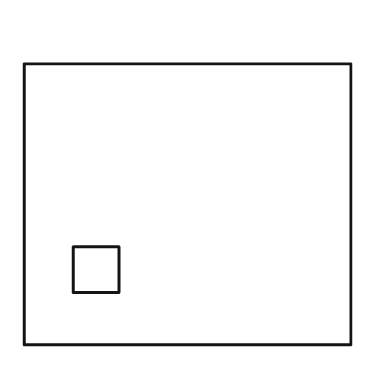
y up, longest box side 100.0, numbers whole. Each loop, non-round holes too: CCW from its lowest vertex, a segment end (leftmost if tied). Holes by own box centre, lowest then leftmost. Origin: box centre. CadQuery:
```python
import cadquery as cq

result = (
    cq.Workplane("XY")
    .moveTo(-50.0, -43.0)
    .lineTo(50.0, -43.0)
    .lineTo(50.0, 43.0)
    .lineTo(-50.0, 43.0)
    .close()
    .moveTo(-35.0, -27.0)
    .lineTo(-21.0, -27.0)
    .lineTo(-21.0, -13.0)
    .lineTo(-35.0, -13.0)
    .close()
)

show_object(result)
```